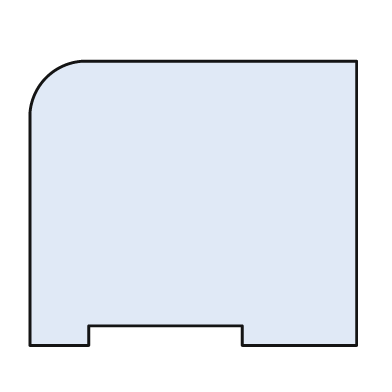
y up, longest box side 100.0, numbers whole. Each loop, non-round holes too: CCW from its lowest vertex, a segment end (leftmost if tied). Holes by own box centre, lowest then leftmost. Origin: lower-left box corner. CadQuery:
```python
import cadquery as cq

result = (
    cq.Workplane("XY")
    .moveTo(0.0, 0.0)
    .lineTo(18.0, 0.0)
    .lineTo(18.0, 6.0)
    .lineTo(65.0, 6.0)
    .lineTo(65.0, 0.0)
    .lineTo(100.0, 0.0)
    .lineTo(100.0, 87.0)
    .lineTo(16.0, 87.0)
    .threePointArc((5.0, 82.0), (0.0, 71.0))
    .close()
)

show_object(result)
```